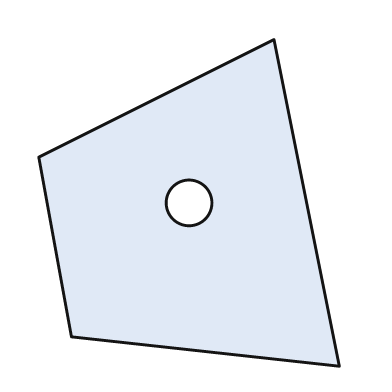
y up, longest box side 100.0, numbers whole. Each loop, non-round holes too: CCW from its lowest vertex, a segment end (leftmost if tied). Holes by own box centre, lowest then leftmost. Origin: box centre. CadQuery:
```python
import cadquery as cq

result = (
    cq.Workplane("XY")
    .moveTo(46.0, -50.0)
    .lineTo(26.0, 50.0)
    .lineTo(-46.0, 14.0)
    .lineTo(-36.0, -41.0)
    .close()
    .moveTo(0.0, 0.0)
    .circle(7.0)
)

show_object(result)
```